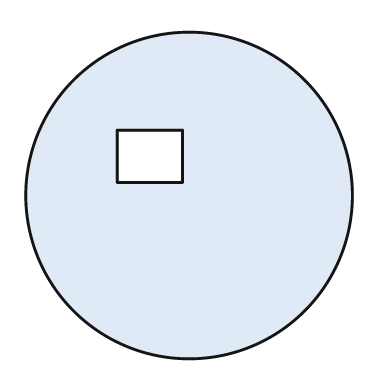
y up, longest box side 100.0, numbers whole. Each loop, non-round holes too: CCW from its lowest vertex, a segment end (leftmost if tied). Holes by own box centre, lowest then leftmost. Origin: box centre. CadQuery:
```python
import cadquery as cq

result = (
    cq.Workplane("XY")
    .moveTo(0.0, 0.0)
    .circle(50.0)
    .moveTo(-22.0, 4.0)
    .lineTo(-2.0, 4.0)
    .lineTo(-2.0, 20.0)
    .lineTo(-22.0, 20.0)
    .close()
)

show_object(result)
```